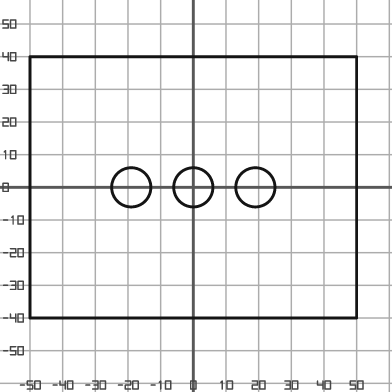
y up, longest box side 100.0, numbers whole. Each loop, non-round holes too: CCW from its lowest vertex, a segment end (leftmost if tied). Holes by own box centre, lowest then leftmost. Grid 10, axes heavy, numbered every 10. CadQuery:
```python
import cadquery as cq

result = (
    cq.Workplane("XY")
    .moveTo(-50.0, -40.0)
    .lineTo(50.0, -40.0)
    .lineTo(50.0, 40.0)
    .lineTo(-50.0, 40.0)
    .close()
    .moveTo(-19.0, 0.0)
    .circle(6.0)
    .moveTo(0.0, 0.0)
    .circle(6.0)
    .moveTo(19.0, 0.0)
    .circle(6.0)
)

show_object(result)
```